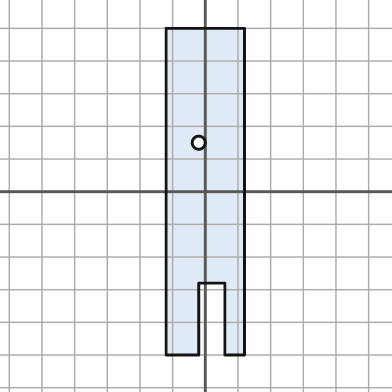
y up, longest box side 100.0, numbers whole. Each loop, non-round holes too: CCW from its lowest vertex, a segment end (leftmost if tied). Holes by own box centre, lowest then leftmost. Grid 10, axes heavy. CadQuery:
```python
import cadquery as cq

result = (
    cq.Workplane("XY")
    .moveTo(-12.0, -50.0)
    .lineTo(-2.0, -50.0)
    .lineTo(-2.0, -28.0)
    .lineTo(6.0, -28.0)
    .lineTo(6.0, -50.0)
    .lineTo(12.0, -50.0)
    .lineTo(12.0, 50.0)
    .lineTo(-12.0, 50.0)
    .close()
    .moveTo(-2.0, 15.0)
    .circle(2.0)
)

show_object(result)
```